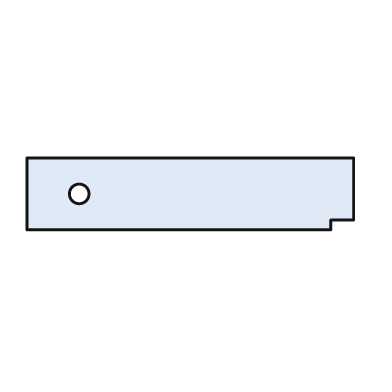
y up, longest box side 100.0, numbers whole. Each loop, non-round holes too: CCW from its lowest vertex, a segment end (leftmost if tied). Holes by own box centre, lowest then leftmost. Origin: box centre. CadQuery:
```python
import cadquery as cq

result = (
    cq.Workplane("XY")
    .moveTo(-50.0, -11.0)
    .lineTo(43.0, -11.0)
    .lineTo(43.0, -8.0)
    .lineTo(50.0, -8.0)
    .lineTo(50.0, 11.0)
    .lineTo(-50.0, 11.0)
    .close()
    .moveTo(-34.0, 0.0)
    .circle(3.0)
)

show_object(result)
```